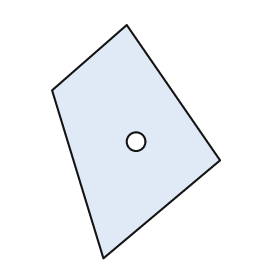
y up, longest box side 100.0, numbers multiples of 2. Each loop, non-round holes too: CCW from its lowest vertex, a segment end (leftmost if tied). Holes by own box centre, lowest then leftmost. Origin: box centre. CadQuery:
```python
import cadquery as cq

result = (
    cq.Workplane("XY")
    .moveTo(-14.0, -50.0)
    .lineTo(36.0, -8.0)
    .lineTo(-4.0, 50.0)
    .lineTo(-36.0, 22.0)
    .close()
    .moveTo(0.0, 0.0)
    .circle(4.0)
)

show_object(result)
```